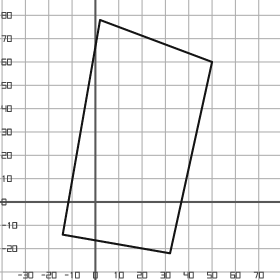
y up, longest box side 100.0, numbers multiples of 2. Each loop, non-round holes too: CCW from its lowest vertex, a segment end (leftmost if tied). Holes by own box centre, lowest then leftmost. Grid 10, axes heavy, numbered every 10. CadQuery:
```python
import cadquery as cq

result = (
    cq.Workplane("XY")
    .moveTo(32.0, -22.0)
    .lineTo(50.0, 60.0)
    .lineTo(2.0, 78.0)
    .lineTo(-14.0, -14.0)
    .close()
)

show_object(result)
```